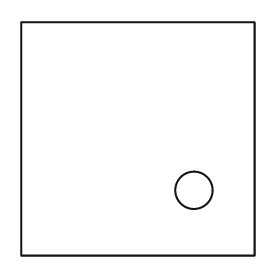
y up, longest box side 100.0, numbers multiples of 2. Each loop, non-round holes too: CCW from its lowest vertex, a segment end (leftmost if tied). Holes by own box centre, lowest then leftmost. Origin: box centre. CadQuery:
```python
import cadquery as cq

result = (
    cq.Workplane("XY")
    .moveTo(-50.0, -50.0)
    .lineTo(50.0, -50.0)
    .lineTo(50.0, 50.0)
    .lineTo(-50.0, 50.0)
    .close()
    .moveTo(24.0, -22.0)
    .circle(8.0)
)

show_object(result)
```